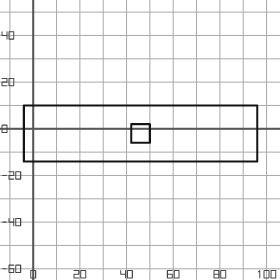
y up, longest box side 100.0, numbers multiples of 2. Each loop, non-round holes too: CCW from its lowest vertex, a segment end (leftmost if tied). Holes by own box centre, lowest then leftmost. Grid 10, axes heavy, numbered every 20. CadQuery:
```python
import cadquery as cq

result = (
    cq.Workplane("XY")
    .moveTo(-4.0, -14.0)
    .lineTo(96.0, -14.0)
    .lineTo(96.0, 10.0)
    .lineTo(-4.0, 10.0)
    .close()
    .moveTo(42.0, -6.0)
    .lineTo(50.0, -6.0)
    .lineTo(50.0, 2.0)
    .lineTo(42.0, 2.0)
    .close()
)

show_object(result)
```